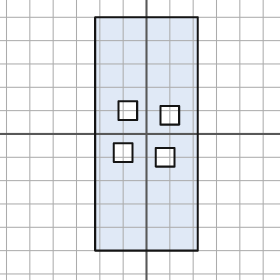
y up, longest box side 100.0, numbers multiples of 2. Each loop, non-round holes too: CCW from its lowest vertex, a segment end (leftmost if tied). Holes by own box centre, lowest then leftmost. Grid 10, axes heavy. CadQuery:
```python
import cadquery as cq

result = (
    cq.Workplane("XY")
    .moveTo(-22.0, -50.0)
    .lineTo(22.0, -50.0)
    .lineTo(22.0, 50.0)
    .lineTo(-22.0, 50.0)
    .close()
    .moveTo(4.0, -14.0)
    .lineTo(12.0, -14.0)
    .lineTo(12.0, -6.0)
    .lineTo(4.0, -6.0)
    .close()
    .moveTo(-14.0, -12.0)
    .lineTo(-6.0, -12.0)
    .lineTo(-6.0, -4.0)
    .lineTo(-14.0, -4.0)
    .close()
    .moveTo(6.0, 4.0)
    .lineTo(14.0, 4.0)
    .lineTo(14.0, 12.0)
    .lineTo(6.0, 12.0)
    .close()
    .moveTo(-12.0, 6.0)
    .lineTo(-4.0, 6.0)
    .lineTo(-4.0, 14.0)
    .lineTo(-12.0, 14.0)
    .close()
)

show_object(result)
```